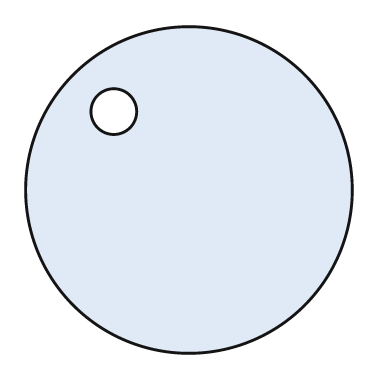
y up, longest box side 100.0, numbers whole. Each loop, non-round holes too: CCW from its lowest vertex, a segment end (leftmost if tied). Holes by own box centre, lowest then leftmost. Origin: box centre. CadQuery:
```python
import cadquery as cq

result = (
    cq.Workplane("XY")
    .moveTo(0.0, 0.0)
    .circle(50.0)
    .moveTo(-23.0, 24.0)
    .circle(7.0)
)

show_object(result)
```